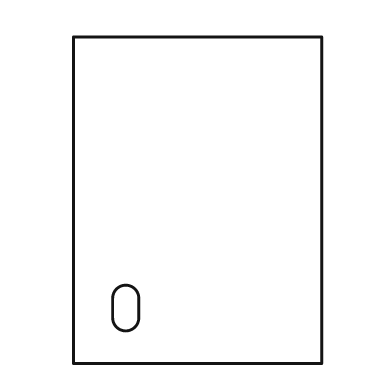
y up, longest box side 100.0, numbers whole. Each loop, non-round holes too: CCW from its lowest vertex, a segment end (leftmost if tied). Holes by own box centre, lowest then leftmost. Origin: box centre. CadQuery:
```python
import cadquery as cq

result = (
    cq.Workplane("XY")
    .moveTo(-38.0, -50.0)
    .lineTo(38.0, -50.0)
    .lineTo(38.0, 50.0)
    .lineTo(-38.0, 50.0)
    .close()
    .moveTo(-26.0, -36.0)
    .threePointArc((-22.0, -40.0), (-18.0, -36.0))
    .lineTo(-18.0, -30.0)
    .threePointArc((-22.0, -26.0), (-26.0, -30.0))
    .close()
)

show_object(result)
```